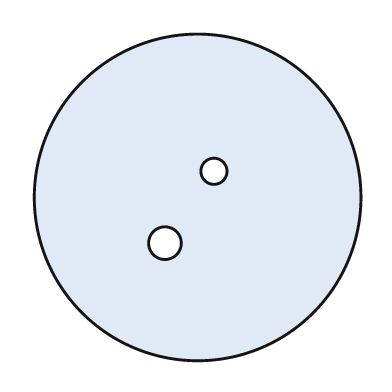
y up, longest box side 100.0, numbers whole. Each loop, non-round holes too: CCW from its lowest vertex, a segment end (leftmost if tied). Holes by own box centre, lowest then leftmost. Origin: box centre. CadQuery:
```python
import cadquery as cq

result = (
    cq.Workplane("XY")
    .moveTo(0.0, 0.0)
    .circle(50.0)
    .moveTo(-10.0, -14.0)
    .circle(5.0)
    .moveTo(5.0, 8.0)
    .circle(4.0)
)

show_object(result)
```